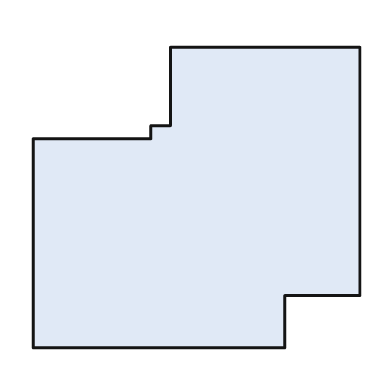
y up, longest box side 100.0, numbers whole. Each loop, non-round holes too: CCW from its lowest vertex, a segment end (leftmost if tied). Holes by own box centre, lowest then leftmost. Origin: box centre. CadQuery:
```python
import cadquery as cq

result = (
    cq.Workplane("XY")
    .moveTo(-50.0, -46.0)
    .lineTo(27.0, -46.0)
    .lineTo(27.0, -30.0)
    .lineTo(50.0, -30.0)
    .lineTo(50.0, 46.0)
    .lineTo(-8.0, 46.0)
    .lineTo(-8.0, 22.0)
    .lineTo(-14.0, 22.0)
    .lineTo(-14.0, 18.0)
    .lineTo(-50.0, 18.0)
    .close()
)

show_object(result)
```